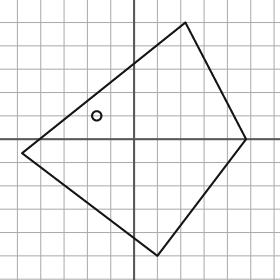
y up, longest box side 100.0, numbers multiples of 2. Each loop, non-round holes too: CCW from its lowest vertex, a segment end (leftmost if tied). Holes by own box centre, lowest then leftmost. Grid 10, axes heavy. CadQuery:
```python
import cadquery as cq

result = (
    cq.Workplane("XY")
    .moveTo(10.0, -50.0)
    .lineTo(48.0, 0.0)
    .lineTo(22.0, 50.0)
    .lineTo(-48.0, -6.0)
    .close()
    .moveTo(-16.0, 10.0)
    .circle(2.0)
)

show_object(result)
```